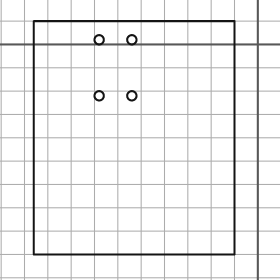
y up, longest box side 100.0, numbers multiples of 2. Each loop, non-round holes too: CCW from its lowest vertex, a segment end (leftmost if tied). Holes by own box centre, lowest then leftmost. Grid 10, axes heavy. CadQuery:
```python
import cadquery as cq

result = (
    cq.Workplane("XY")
    .moveTo(-96.0, -90.0)
    .lineTo(-10.0, -90.0)
    .lineTo(-10.0, 10.0)
    .lineTo(-96.0, 10.0)
    .close()
    .moveTo(-68.0, -22.0)
    .circle(2.0)
    .moveTo(-54.0, -22.0)
    .circle(2.0)
    .moveTo(-68.0, 2.0)
    .circle(2.0)
    .moveTo(-54.0, 2.0)
    .circle(2.0)
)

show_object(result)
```